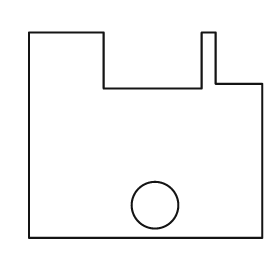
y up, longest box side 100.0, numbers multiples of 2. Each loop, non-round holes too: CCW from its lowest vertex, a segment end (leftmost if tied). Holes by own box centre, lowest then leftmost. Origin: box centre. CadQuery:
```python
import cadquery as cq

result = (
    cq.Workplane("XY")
    .moveTo(-50.0, -44.0)
    .lineTo(50.0, -44.0)
    .lineTo(50.0, 22.0)
    .lineTo(30.0, 22.0)
    .lineTo(30.0, 44.0)
    .lineTo(24.0, 44.0)
    .lineTo(24.0, 20.0)
    .lineTo(-18.0, 20.0)
    .lineTo(-18.0, 44.0)
    .lineTo(-50.0, 44.0)
    .close()
    .moveTo(4.0, -30.0)
    .circle(10.0)
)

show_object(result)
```